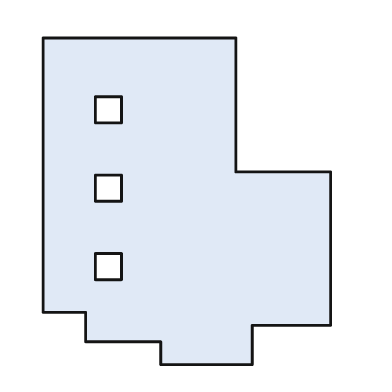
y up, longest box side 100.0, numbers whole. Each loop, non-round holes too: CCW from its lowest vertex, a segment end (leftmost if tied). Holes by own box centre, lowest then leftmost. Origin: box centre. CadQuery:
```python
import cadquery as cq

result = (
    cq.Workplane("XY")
    .moveTo(-8.0, -50.0)
    .lineTo(20.0, -50.0)
    .lineTo(20.0, -38.0)
    .lineTo(44.0, -38.0)
    .lineTo(44.0, 9.0)
    .lineTo(15.0, 9.0)
    .lineTo(15.0, 50.0)
    .lineTo(-44.0, 50.0)
    .lineTo(-44.0, -34.0)
    .lineTo(-31.0, -34.0)
    .lineTo(-31.0, -43.0)
    .lineTo(-8.0, -43.0)
    .close()
    .moveTo(-28.0, -24.0)
    .lineTo(-20.0, -24.0)
    .lineTo(-20.0, -16.0)
    .lineTo(-28.0, -16.0)
    .close()
    .moveTo(-28.0, 0.0)
    .lineTo(-20.0, 0.0)
    .lineTo(-20.0, 8.0)
    .lineTo(-28.0, 8.0)
    .close()
    .moveTo(-28.0, 24.0)
    .lineTo(-20.0, 24.0)
    .lineTo(-20.0, 32.0)
    .lineTo(-28.0, 32.0)
    .close()
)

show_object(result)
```